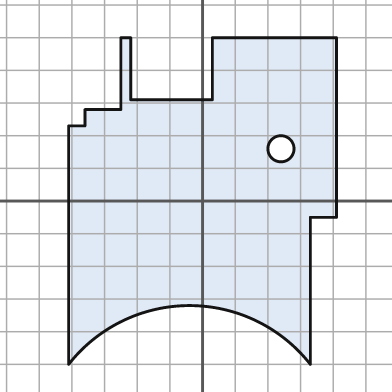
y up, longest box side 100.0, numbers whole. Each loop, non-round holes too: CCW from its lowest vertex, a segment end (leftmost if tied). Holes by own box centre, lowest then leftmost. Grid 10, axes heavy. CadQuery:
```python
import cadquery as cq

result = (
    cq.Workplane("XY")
    .moveTo(-41.0, -50.0)
    .threePointArc((-4.0, -32.0), (33.0, -50.0))
    .lineTo(33.0, -5.0)
    .lineTo(41.0, -5.0)
    .lineTo(41.0, 50.0)
    .lineTo(3.0, 50.0)
    .lineTo(3.0, 31.0)
    .lineTo(-22.0, 31.0)
    .lineTo(-22.0, 50.0)
    .lineTo(-25.0, 50.0)
    .lineTo(-25.0, 28.0)
    .lineTo(-36.0, 28.0)
    .lineTo(-36.0, 23.0)
    .lineTo(-41.0, 23.0)
    .close()
    .moveTo(24.0, 16.0)
    .circle(4.0)
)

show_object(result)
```